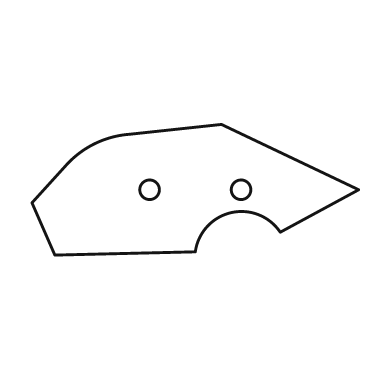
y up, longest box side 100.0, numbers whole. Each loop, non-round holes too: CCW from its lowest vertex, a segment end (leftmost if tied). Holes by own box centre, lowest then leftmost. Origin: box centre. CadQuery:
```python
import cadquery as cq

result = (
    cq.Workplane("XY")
    .moveTo(-43.0, -20.0)
    .lineTo(0.0, -19.0)
    .threePointArc((11.0, -7.0), (26.0, -13.0))
    .lineTo(50.0, 0.0)
    .lineTo(8.0, 20.0)
    .lineTo(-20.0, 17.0)
    .threePointArc((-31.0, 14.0), (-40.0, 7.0))
    .lineTo(-50.0, -4.0)
    .close()
    .moveTo(-14.0, 0.0)
    .circle(3.0)
    .moveTo(14.0, 0.0)
    .circle(3.0)
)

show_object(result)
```